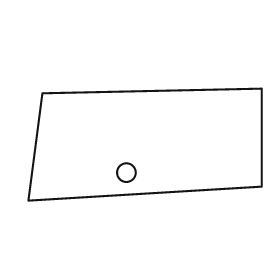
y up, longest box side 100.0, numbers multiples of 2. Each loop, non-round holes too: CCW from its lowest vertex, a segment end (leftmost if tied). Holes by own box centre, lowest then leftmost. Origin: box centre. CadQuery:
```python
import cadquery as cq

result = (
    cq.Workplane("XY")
    .moveTo(-50.0, -24.0)
    .lineTo(50.0, -18.0)
    .lineTo(50.0, 24.0)
    .lineTo(-44.0, 22.0)
    .close()
    .moveTo(-8.0, -12.0)
    .circle(4.0)
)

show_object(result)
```